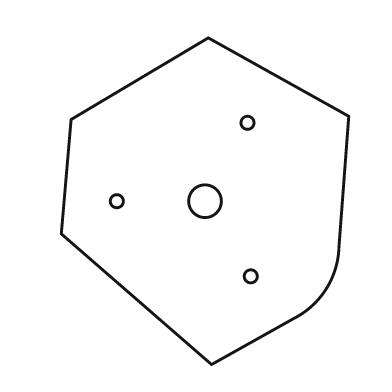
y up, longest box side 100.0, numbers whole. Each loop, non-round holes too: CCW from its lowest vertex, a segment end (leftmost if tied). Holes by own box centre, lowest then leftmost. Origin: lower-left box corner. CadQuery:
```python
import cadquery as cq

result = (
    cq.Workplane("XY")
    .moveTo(46.0, 0.0)
    .lineTo(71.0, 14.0)
    .threePointArc((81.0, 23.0), (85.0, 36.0))
    .lineTo(88.0, 76.0)
    .lineTo(45.0, 100.0)
    .lineTo(3.0, 75.0)
    .lineTo(0.0, 40.0)
    .close()
    .moveTo(58.0, 27.0)
    .circle(2.0)
    .moveTo(17.0, 50.0)
    .circle(2.0)
    .moveTo(44.0, 50.0)
    .circle(5.0)
    .moveTo(57.0, 74.0)
    .circle(2.0)
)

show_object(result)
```